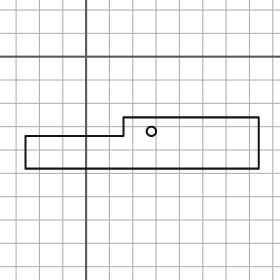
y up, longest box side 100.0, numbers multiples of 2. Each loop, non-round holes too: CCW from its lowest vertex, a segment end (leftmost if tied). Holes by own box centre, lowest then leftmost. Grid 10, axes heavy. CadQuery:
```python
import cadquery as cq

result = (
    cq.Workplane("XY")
    .moveTo(-26.0, -48.0)
    .lineTo(74.0, -48.0)
    .lineTo(74.0, -26.0)
    .lineTo(16.0, -26.0)
    .lineTo(16.0, -34.0)
    .lineTo(-26.0, -34.0)
    .close()
    .moveTo(28.0, -32.0)
    .circle(2.0)
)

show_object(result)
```